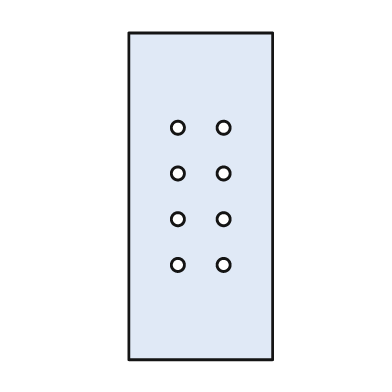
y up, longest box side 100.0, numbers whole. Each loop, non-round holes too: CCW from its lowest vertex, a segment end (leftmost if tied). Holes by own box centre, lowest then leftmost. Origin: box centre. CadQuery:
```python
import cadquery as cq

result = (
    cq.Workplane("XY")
    .moveTo(-22.0, -50.0)
    .lineTo(22.0, -50.0)
    .lineTo(22.0, 50.0)
    .lineTo(-22.0, 50.0)
    .close()
    .moveTo(-7.0, -21.0)
    .circle(2.0)
    .moveTo(7.0, -21.0)
    .circle(2.0)
    .moveTo(-7.0, -7.0)
    .circle(2.0)
    .moveTo(7.0, -7.0)
    .circle(2.0)
    .moveTo(-7.0, 7.0)
    .circle(2.0)
    .moveTo(7.0, 7.0)
    .circle(2.0)
    .moveTo(-7.0, 21.0)
    .circle(2.0)
    .moveTo(7.0, 21.0)
    .circle(2.0)
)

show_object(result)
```